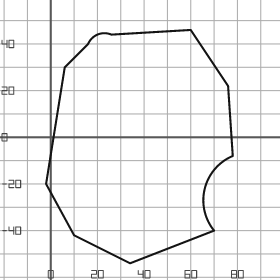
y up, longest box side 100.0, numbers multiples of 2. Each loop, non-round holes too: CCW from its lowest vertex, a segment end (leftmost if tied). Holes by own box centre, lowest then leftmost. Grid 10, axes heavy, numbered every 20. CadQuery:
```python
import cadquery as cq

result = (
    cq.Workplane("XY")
    .moveTo(34.0, -54.0)
    .lineTo(70.0, -40.0)
    .threePointArc((66.0, -22.0), (78.0, -8.0))
    .lineTo(76.0, 22.0)
    .lineTo(60.0, 46.0)
    .lineTo(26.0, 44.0)
    .threePointArc((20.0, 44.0), (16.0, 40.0))
    .lineTo(6.0, 30.0)
    .lineTo(-2.0, -20.0)
    .lineTo(10.0, -42.0)
    .close()
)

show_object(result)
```